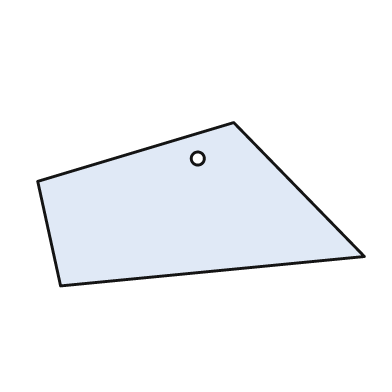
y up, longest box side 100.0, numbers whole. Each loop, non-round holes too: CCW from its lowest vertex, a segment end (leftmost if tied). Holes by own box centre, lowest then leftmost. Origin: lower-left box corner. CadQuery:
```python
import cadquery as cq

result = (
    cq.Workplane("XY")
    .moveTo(7.0, 0.0)
    .lineTo(100.0, 9.0)
    .lineTo(60.0, 50.0)
    .lineTo(0.0, 32.0)
    .close()
    .moveTo(49.0, 39.0)
    .circle(2.0)
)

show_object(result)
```